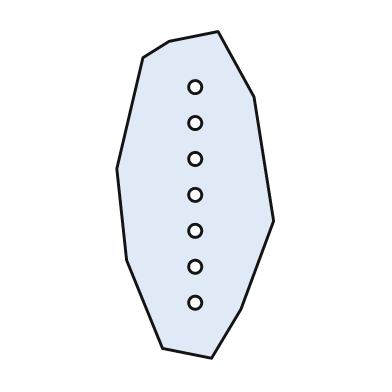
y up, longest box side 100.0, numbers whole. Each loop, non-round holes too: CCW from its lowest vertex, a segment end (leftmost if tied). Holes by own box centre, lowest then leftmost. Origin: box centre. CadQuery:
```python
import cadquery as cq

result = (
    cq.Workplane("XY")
    .moveTo(5.0, -50.0)
    .lineTo(14.0, -35.0)
    .lineTo(24.0, -8.0)
    .lineTo(18.0, 30.0)
    .lineTo(7.0, 50.0)
    .lineTo(-8.0, 47.0)
    .lineTo(-16.0, 42.0)
    .lineTo(-24.0, 8.0)
    .lineTo(-21.0, -20.0)
    .lineTo(-10.0, -47.0)
    .close()
    .moveTo(0.0, -33.0)
    .circle(2.0)
    .moveTo(0.0, -22.0)
    .circle(2.0)
    .moveTo(0.0, -11.0)
    .circle(2.0)
    .moveTo(0.0, 0.0)
    .circle(2.0)
    .moveTo(0.0, 11.0)
    .circle(2.0)
    .moveTo(0.0, 22.0)
    .circle(2.0)
    .moveTo(0.0, 33.0)
    .circle(2.0)
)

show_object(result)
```